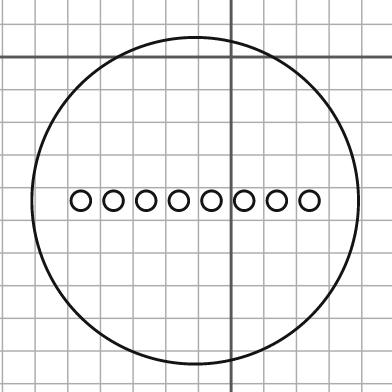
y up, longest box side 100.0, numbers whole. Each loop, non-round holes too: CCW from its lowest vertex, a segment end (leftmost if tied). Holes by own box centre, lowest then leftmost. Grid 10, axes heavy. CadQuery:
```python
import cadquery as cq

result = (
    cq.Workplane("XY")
    .moveTo(-11.0, -44.0)
    .circle(50.0)
    .moveTo(-46.0, -44.0)
    .circle(3.0)
    .moveTo(-36.0, -44.0)
    .circle(3.0)
    .moveTo(-26.0, -44.0)
    .circle(3.0)
    .moveTo(-16.0, -44.0)
    .circle(3.0)
    .moveTo(-6.0, -44.0)
    .circle(3.0)
    .moveTo(4.0, -44.0)
    .circle(3.0)
    .moveTo(14.0, -44.0)
    .circle(3.0)
    .moveTo(24.0, -44.0)
    .circle(3.0)
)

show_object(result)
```